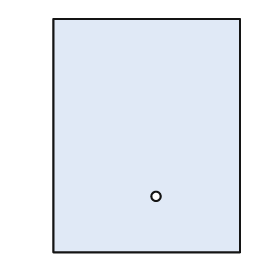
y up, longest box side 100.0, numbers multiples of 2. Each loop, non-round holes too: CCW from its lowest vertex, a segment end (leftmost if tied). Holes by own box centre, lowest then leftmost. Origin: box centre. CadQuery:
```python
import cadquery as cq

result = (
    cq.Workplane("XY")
    .moveTo(-40.0, -50.0)
    .lineTo(40.0, -50.0)
    .lineTo(40.0, 50.0)
    .lineTo(-40.0, 50.0)
    .close()
    .moveTo(4.0, -26.0)
    .circle(2.0)
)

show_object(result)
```